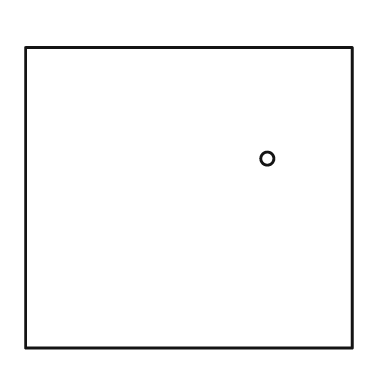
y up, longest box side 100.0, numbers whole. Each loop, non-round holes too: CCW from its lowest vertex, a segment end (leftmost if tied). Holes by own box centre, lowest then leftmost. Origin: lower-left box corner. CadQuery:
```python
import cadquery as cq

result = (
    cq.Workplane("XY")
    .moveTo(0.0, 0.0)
    .lineTo(100.0, 0.0)
    .lineTo(100.0, 92.0)
    .lineTo(0.0, 92.0)
    .close()
    .moveTo(74.0, 58.0)
    .circle(2.0)
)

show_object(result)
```